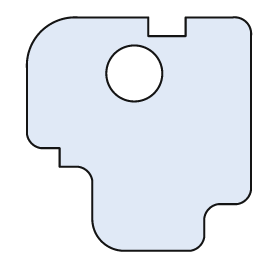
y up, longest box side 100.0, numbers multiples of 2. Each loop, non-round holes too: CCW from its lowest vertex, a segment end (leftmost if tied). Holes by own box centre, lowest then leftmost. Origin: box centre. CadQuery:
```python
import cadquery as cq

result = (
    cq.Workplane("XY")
    .moveTo(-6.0, -50.0)
    .lineTo(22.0, -50.0)
    .threePointArc((26.0, -48.0), (28.0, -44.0))
    .lineTo(28.0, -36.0)
    .threePointArc((30.0, -32.0), (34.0, -30.0))
    .lineTo(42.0, -30.0)
    .threePointArc((46.0, -28.0), (48.0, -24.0))
    .lineTo(48.0, 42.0)
    .threePointArc((46.0, 48.0), (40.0, 50.0))
    .lineTo(20.0, 50.0)
    .lineTo(20.0, 42.0)
    .lineTo(4.0, 42.0)
    .lineTo(4.0, 50.0)
    .lineTo(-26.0, 50.0)
    .threePointArc((-42.0, 44.0), (-48.0, 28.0))
    .lineTo(-48.0, 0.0)
    .threePointArc((-46.0, -4.0), (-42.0, -6.0))
    .lineTo(-34.0, -6.0)
    .lineTo(-34.0, -14.0)
    .lineTo(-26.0, -14.0)
    .threePointArc((-22.0, -16.0), (-20.0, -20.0))
    .lineTo(-20.0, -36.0)
    .threePointArc((-16.0, -46.0), (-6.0, -50.0))
    .close()
    .moveTo(-2.0, 26.0)
    .circle(12.0)
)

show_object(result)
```